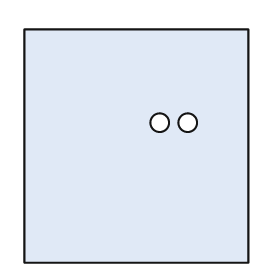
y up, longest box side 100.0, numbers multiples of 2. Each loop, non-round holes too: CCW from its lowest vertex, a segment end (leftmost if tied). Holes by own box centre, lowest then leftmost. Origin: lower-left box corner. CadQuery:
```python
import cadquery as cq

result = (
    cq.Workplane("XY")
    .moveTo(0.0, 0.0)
    .lineTo(96.0, 0.0)
    .lineTo(96.0, 100.0)
    .lineTo(0.0, 100.0)
    .close()
    .moveTo(58.0, 60.0)
    .circle(4.0)
    .moveTo(70.0, 60.0)
    .circle(4.0)
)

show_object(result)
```